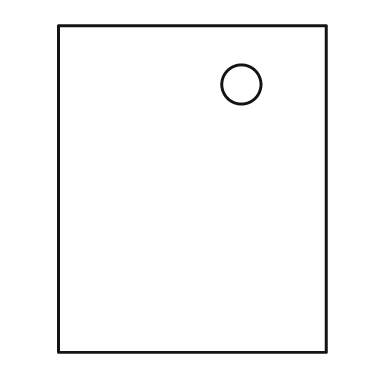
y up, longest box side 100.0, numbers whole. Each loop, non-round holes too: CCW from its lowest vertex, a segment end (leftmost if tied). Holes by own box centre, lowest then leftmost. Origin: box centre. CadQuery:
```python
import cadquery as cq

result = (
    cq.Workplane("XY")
    .moveTo(-41.0, -50.0)
    .lineTo(41.0, -50.0)
    .lineTo(41.0, 50.0)
    .lineTo(-41.0, 50.0)
    .close()
    .moveTo(15.0, 32.0)
    .circle(6.0)
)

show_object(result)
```